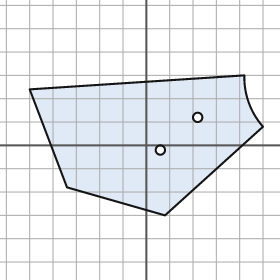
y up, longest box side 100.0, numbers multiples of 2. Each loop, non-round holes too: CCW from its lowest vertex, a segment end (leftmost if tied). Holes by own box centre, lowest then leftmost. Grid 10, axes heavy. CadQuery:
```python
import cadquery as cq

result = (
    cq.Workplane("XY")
    .moveTo(8.0, -30.0)
    .lineTo(50.0, 8.0)
    .threePointArc((44.0, 18.0), (42.0, 30.0))
    .lineTo(-50.0, 24.0)
    .lineTo(-34.0, -18.0)
    .close()
    .moveTo(6.0, -2.0)
    .circle(2.0)
    .moveTo(22.0, 12.0)
    .circle(2.0)
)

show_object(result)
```